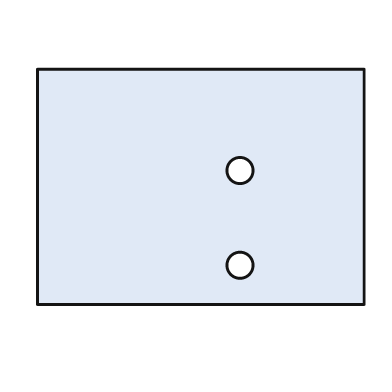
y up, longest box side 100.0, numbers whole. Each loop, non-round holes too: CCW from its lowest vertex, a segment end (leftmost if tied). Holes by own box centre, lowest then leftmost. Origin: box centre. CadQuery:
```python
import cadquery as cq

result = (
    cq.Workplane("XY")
    .moveTo(-50.0, -36.0)
    .lineTo(50.0, -36.0)
    .lineTo(50.0, 36.0)
    .lineTo(-50.0, 36.0)
    .close()
    .moveTo(12.0, -24.0)
    .circle(4.0)
    .moveTo(12.0, 5.0)
    .circle(4.0)
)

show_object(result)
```